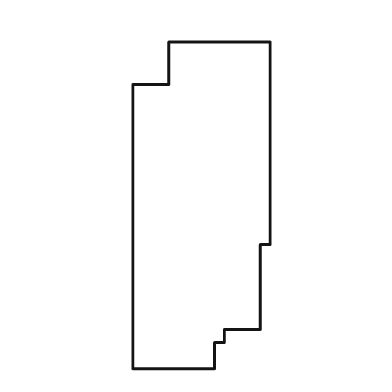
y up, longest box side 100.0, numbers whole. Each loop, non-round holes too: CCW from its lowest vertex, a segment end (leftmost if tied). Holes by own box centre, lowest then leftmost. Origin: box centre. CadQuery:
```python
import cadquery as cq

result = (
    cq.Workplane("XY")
    .moveTo(-21.0, -50.0)
    .lineTo(4.0, -50.0)
    .lineTo(4.0, -42.0)
    .lineTo(7.0, -42.0)
    .lineTo(7.0, -38.0)
    .lineTo(18.0, -38.0)
    .lineTo(18.0, -12.0)
    .lineTo(21.0, -12.0)
    .lineTo(21.0, 50.0)
    .lineTo(-10.0, 50.0)
    .lineTo(-10.0, 37.0)
    .lineTo(-21.0, 37.0)
    .close()
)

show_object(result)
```